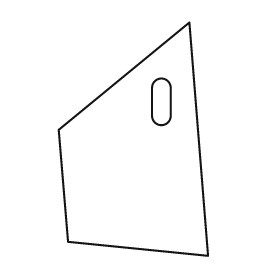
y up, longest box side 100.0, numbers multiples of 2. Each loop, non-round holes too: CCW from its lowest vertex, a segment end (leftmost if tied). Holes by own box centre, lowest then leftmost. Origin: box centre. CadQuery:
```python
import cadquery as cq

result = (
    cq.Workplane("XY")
    .moveTo(32.0, -50.0)
    .lineTo(24.0, 50.0)
    .lineTo(-32.0, 4.0)
    .lineTo(-28.0, -44.0)
    .close()
    .moveTo(8.0, 10.0)
    .threePointArc((12.0, 6.0), (16.0, 10.0))
    .lineTo(16.0, 22.0)
    .threePointArc((12.0, 26.0), (8.0, 22.0))
    .close()
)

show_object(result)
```